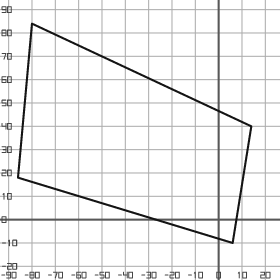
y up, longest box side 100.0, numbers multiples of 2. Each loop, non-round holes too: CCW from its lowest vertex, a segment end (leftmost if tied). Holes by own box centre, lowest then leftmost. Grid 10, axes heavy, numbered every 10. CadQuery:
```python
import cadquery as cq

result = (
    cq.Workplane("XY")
    .moveTo(6.0, -10.0)
    .lineTo(14.0, 40.0)
    .lineTo(-80.0, 84.0)
    .lineTo(-86.0, 18.0)
    .close()
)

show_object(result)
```